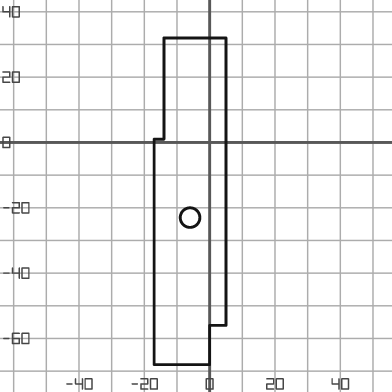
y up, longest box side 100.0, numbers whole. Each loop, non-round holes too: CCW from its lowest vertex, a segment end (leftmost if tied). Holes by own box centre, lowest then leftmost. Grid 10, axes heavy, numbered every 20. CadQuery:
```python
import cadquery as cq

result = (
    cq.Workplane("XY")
    .moveTo(-17.0, -68.0)
    .lineTo(0.0, -68.0)
    .lineTo(0.0, -56.0)
    .lineTo(5.0, -56.0)
    .lineTo(5.0, 32.0)
    .lineTo(-14.0, 32.0)
    .lineTo(-14.0, 1.0)
    .lineTo(-17.0, 1.0)
    .close()
    .moveTo(-6.0, -23.0)
    .circle(3.0)
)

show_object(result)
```